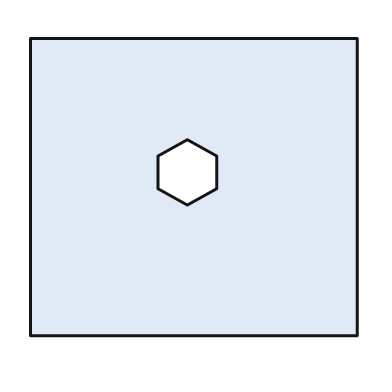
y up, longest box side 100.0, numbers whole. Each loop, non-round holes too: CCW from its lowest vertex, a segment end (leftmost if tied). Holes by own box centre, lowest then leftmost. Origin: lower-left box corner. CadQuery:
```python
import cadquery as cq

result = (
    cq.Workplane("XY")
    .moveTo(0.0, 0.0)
    .lineTo(100.0, 0.0)
    .lineTo(100.0, 91.0)
    .lineTo(0.0, 91.0)
    .close()
    .moveTo(48.0, 40.0)
    .lineTo(57.0, 45.0)
    .lineTo(57.0, 55.0)
    .lineTo(48.0, 60.0)
    .lineTo(39.0, 55.0)
    .lineTo(39.0, 45.0)
    .close()
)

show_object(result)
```